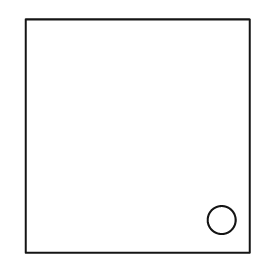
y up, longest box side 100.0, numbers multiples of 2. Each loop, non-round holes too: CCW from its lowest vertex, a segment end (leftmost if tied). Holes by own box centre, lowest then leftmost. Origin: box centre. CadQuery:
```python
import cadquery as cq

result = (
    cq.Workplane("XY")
    .moveTo(-48.0, -50.0)
    .lineTo(48.0, -50.0)
    .lineTo(48.0, 50.0)
    .lineTo(-48.0, 50.0)
    .close()
    .moveTo(36.0, -36.0)
    .circle(6.0)
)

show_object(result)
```